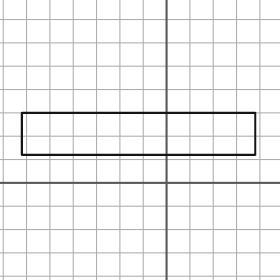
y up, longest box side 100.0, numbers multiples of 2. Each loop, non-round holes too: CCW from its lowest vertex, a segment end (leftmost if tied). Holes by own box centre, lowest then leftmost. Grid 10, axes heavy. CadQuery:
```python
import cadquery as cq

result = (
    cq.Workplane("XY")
    .moveTo(-62.0, 12.0)
    .lineTo(38.0, 12.0)
    .lineTo(38.0, 30.0)
    .lineTo(-62.0, 30.0)
    .close()
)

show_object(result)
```